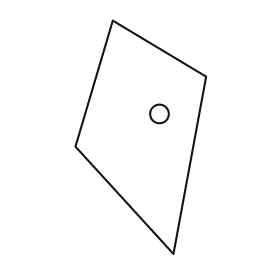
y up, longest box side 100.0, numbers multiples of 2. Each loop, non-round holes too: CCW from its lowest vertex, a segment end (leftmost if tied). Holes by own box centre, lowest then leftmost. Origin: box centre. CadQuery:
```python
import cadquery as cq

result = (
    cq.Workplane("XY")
    .moveTo(14.0, -50.0)
    .lineTo(28.0, 26.0)
    .lineTo(-12.0, 50.0)
    .lineTo(-28.0, -4.0)
    .close()
    .moveTo(8.0, 10.0)
    .circle(4.0)
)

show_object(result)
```